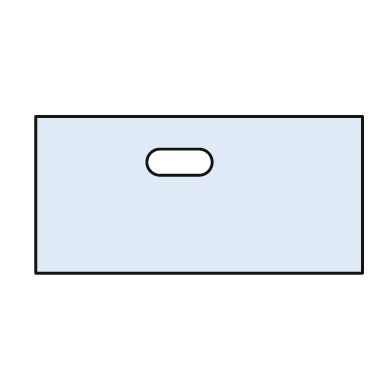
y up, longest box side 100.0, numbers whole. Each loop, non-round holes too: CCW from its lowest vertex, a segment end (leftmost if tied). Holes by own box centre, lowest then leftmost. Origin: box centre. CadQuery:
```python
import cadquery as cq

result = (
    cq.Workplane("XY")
    .moveTo(-50.0, -24.0)
    .lineTo(50.0, -24.0)
    .lineTo(50.0, 24.0)
    .lineTo(-50.0, 24.0)
    .close()
    .moveTo(-12.0, 6.0)
    .lineTo(0.0, 6.0)
    .threePointArc((4.0, 10.0), (0.0, 14.0))
    .lineTo(-12.0, 14.0)
    .threePointArc((-16.0, 10.0), (-12.0, 6.0))
    .close()
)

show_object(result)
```